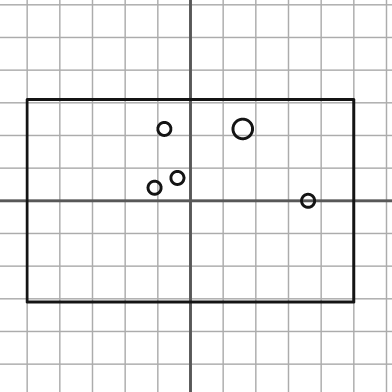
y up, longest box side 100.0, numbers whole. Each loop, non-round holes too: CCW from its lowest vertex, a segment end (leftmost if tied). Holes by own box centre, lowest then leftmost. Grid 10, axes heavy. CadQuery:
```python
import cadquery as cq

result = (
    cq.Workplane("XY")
    .moveTo(-50.0, -31.0)
    .lineTo(50.0, -31.0)
    .lineTo(50.0, 31.0)
    .lineTo(-50.0, 31.0)
    .close()
    .moveTo(36.0, 0.0)
    .circle(2.0)
    .moveTo(-11.0, 4.0)
    .circle(2.0)
    .moveTo(-4.0, 7.0)
    .circle(2.0)
    .moveTo(-8.0, 22.0)
    .circle(2.0)
    .moveTo(16.0, 22.0)
    .circle(3.0)
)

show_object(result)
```